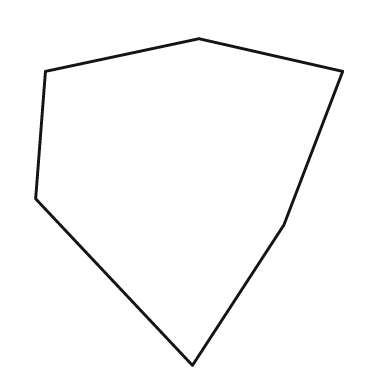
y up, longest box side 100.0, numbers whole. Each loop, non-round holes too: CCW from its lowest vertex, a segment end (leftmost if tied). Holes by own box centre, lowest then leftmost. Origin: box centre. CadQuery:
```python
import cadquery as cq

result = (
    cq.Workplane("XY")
    .moveTo(1.0, -50.0)
    .lineTo(29.0, -7.0)
    .lineTo(47.0, 40.0)
    .lineTo(3.0, 50.0)
    .lineTo(-44.0, 40.0)
    .lineTo(-47.0, 1.0)
    .close()
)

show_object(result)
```